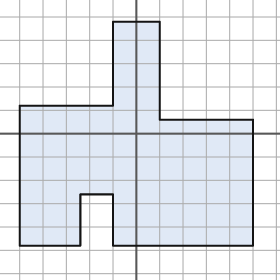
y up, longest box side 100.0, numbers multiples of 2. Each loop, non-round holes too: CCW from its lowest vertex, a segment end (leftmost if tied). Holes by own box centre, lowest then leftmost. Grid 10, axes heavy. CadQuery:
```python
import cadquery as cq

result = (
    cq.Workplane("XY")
    .moveTo(-50.0, -48.0)
    .lineTo(-24.0, -48.0)
    .lineTo(-24.0, -26.0)
    .lineTo(-10.0, -26.0)
    .lineTo(-10.0, -48.0)
    .lineTo(50.0, -48.0)
    .lineTo(50.0, 6.0)
    .lineTo(10.0, 6.0)
    .lineTo(10.0, 48.0)
    .lineTo(-10.0, 48.0)
    .lineTo(-10.0, 12.0)
    .lineTo(-50.0, 12.0)
    .close()
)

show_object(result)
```